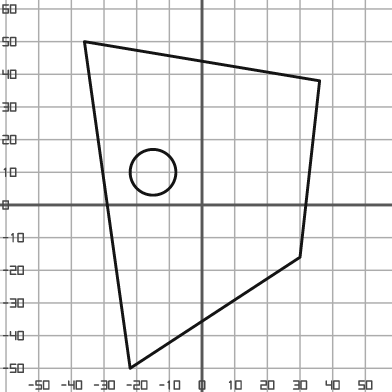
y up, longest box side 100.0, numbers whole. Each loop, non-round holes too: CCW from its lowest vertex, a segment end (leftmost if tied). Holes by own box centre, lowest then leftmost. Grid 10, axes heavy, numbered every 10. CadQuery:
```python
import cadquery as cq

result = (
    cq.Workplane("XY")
    .moveTo(-22.0, -50.0)
    .lineTo(30.0, -16.0)
    .lineTo(36.0, 38.0)
    .lineTo(-36.0, 50.0)
    .close()
    .moveTo(-15.0, 10.0)
    .circle(7.0)
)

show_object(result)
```